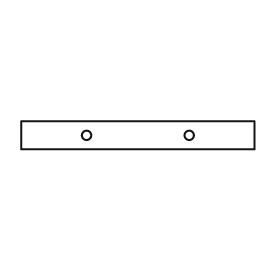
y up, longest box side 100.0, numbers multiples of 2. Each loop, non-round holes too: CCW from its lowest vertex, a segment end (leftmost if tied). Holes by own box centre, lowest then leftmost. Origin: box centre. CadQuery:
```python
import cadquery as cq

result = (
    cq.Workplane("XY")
    .moveTo(-50.0, -6.0)
    .lineTo(50.0, -6.0)
    .lineTo(50.0, 6.0)
    .lineTo(-50.0, 6.0)
    .close()
    .moveTo(-22.0, 0.0)
    .circle(2.0)
    .moveTo(22.0, 0.0)
    .circle(2.0)
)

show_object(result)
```